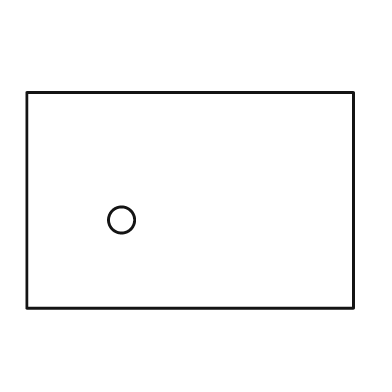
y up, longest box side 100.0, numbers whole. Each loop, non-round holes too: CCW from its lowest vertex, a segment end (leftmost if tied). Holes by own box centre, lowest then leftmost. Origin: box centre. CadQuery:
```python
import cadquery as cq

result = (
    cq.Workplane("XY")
    .moveTo(-50.0, -33.0)
    .lineTo(50.0, -33.0)
    .lineTo(50.0, 33.0)
    .lineTo(-50.0, 33.0)
    .close()
    .moveTo(-21.0, -6.0)
    .circle(4.0)
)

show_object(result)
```